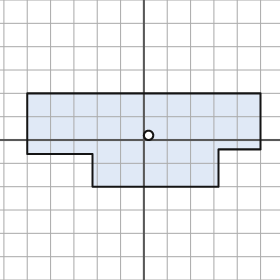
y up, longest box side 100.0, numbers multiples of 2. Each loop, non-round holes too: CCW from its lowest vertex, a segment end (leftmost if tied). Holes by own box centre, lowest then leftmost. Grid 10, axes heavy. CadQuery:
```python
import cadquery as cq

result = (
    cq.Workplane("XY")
    .moveTo(-22.0, -20.0)
    .lineTo(32.0, -20.0)
    .lineTo(32.0, -4.0)
    .lineTo(50.0, -4.0)
    .lineTo(50.0, 20.0)
    .lineTo(-50.0, 20.0)
    .lineTo(-50.0, -6.0)
    .lineTo(-22.0, -6.0)
    .close()
    .moveTo(2.0, 2.0)
    .circle(2.0)
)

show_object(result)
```